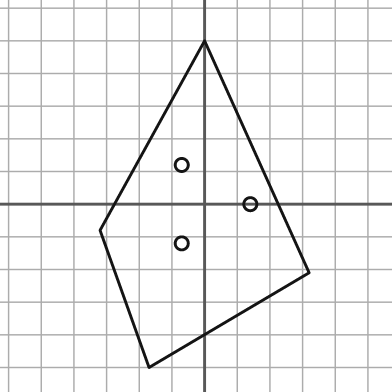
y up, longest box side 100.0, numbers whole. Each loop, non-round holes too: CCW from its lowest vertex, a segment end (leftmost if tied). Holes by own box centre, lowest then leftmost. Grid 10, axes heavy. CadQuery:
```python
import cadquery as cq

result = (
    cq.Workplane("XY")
    .moveTo(-17.0, -50.0)
    .lineTo(32.0, -21.0)
    .lineTo(0.0, 50.0)
    .lineTo(-32.0, -8.0)
    .close()
    .moveTo(-7.0, -12.0)
    .circle(2.0)
    .moveTo(14.0, 0.0)
    .circle(2.0)
    .moveTo(-7.0, 12.0)
    .circle(2.0)
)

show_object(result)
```